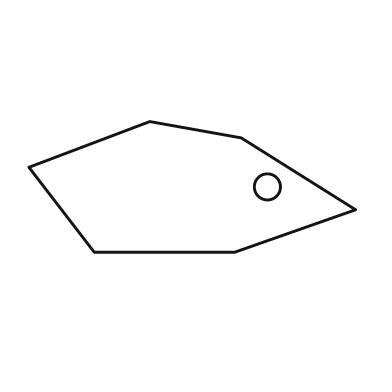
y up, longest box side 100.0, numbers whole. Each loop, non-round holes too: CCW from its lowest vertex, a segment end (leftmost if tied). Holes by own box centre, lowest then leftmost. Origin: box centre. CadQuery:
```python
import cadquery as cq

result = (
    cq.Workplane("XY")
    .moveTo(-30.0, -20.0)
    .lineTo(13.0, -20.0)
    .lineTo(50.0, -7.0)
    .lineTo(15.0, 15.0)
    .lineTo(-13.0, 20.0)
    .lineTo(-50.0, 6.0)
    .close()
    .moveTo(23.0, 0.0)
    .circle(4.0)
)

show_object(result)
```